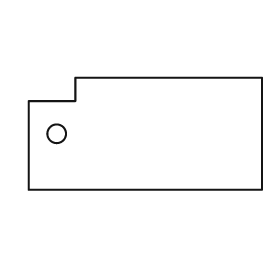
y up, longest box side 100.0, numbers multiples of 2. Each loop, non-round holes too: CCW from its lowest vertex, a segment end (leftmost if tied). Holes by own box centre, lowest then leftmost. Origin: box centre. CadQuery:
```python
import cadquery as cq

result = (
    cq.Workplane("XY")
    .moveTo(-50.0, -24.0)
    .lineTo(50.0, -24.0)
    .lineTo(50.0, 24.0)
    .lineTo(-30.0, 24.0)
    .lineTo(-30.0, 14.0)
    .lineTo(-50.0, 14.0)
    .close()
    .moveTo(-38.0, 0.0)
    .circle(4.0)
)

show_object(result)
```